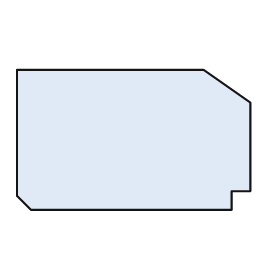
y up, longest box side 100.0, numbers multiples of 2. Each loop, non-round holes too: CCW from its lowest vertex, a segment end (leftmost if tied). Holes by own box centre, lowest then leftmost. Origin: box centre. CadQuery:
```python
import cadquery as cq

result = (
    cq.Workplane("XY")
    .moveTo(-44.0, -30.0)
    .lineTo(42.0, -30.0)
    .lineTo(42.0, -22.0)
    .lineTo(50.0, -22.0)
    .lineTo(50.0, 16.0)
    .lineTo(30.0, 30.0)
    .lineTo(-50.0, 30.0)
    .lineTo(-50.0, -24.0)
    .close()
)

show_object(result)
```